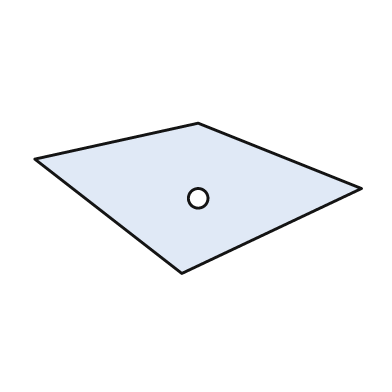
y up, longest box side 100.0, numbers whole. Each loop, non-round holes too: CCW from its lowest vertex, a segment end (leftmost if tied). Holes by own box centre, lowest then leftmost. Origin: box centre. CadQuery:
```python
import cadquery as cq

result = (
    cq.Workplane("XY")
    .moveTo(-5.0, -23.0)
    .lineTo(50.0, 3.0)
    .lineTo(0.0, 23.0)
    .lineTo(-50.0, 12.0)
    .close()
    .moveTo(0.0, 0.0)
    .circle(3.0)
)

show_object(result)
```